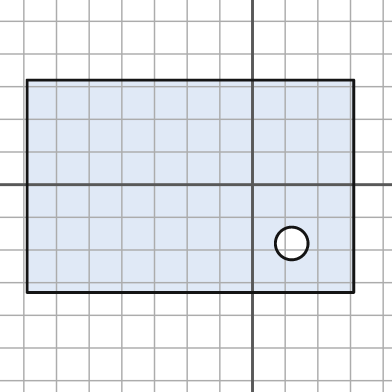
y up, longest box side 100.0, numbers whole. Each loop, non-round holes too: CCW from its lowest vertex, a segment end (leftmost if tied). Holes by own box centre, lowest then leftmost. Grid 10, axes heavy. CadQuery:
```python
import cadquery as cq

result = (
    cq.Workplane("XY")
    .moveTo(-69.0, -33.0)
    .lineTo(31.0, -33.0)
    .lineTo(31.0, 32.0)
    .lineTo(-69.0, 32.0)
    .close()
    .moveTo(12.0, -18.0)
    .circle(5.0)
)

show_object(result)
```